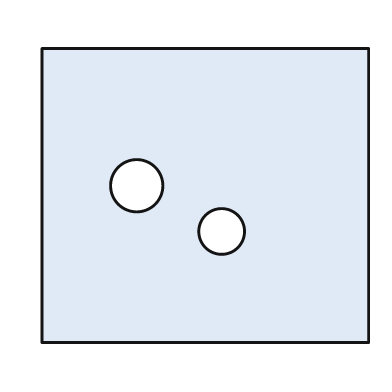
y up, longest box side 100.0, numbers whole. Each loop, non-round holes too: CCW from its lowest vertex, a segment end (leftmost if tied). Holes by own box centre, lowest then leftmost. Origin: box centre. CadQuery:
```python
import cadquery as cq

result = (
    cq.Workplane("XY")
    .moveTo(-50.0, -45.0)
    .lineTo(50.0, -45.0)
    .lineTo(50.0, 45.0)
    .lineTo(-50.0, 45.0)
    .close()
    .moveTo(5.0, -11.0)
    .circle(7.0)
    .moveTo(-21.0, 3.0)
    .circle(8.0)
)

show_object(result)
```